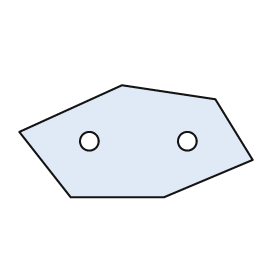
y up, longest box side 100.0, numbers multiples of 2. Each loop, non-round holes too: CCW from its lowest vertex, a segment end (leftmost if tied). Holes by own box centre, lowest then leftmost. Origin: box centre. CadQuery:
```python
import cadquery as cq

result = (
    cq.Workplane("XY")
    .moveTo(-28.0, -24.0)
    .lineTo(12.0, -24.0)
    .lineTo(50.0, -8.0)
    .lineTo(34.0, 18.0)
    .lineTo(-6.0, 24.0)
    .lineTo(-50.0, 4.0)
    .close()
    .moveTo(-20.0, 0.0)
    .circle(4.0)
    .moveTo(22.0, 0.0)
    .circle(4.0)
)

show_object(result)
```